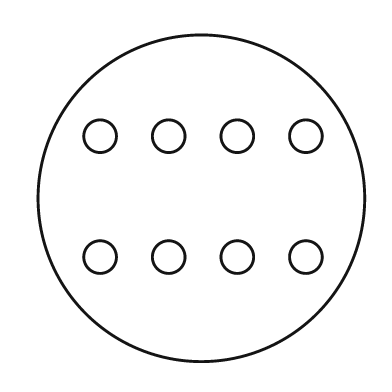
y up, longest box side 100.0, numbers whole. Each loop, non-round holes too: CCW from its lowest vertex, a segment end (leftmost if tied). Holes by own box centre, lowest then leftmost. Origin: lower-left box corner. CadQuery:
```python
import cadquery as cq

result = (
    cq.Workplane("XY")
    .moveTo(50.0, 50.0)
    .circle(50.0)
    .moveTo(19.0, 32.0)
    .circle(5.0)
    .moveTo(40.0, 32.0)
    .circle(5.0)
    .moveTo(61.0, 32.0)
    .circle(5.0)
    .moveTo(82.0, 32.0)
    .circle(5.0)
    .moveTo(19.0, 69.0)
    .circle(5.0)
    .moveTo(40.0, 69.0)
    .circle(5.0)
    .moveTo(61.0, 69.0)
    .circle(5.0)
    .moveTo(82.0, 69.0)
    .circle(5.0)
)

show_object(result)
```